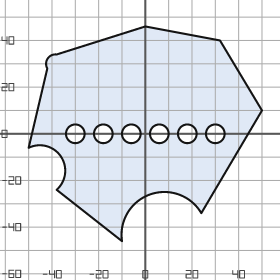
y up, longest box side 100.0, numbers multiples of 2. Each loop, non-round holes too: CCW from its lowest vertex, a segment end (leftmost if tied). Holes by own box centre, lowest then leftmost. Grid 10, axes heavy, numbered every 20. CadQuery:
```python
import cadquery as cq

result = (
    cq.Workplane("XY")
    .moveTo(-10.0, -46.0)
    .threePointArc((2.0, -26.0), (24.0, -34.0))
    .lineTo(50.0, 10.0)
    .lineTo(32.0, 40.0)
    .lineTo(0.0, 46.0)
    .lineTo(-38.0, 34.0)
    .threePointArc((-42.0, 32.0), (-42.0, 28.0))
    .lineTo(-50.0, -6.0)
    .threePointArc((-36.0, -10.0), (-38.0, -24.0))
    .close()
    .moveTo(-30.0, 0.0)
    .circle(4.0)
    .moveTo(-18.0, 0.0)
    .circle(4.0)
    .moveTo(-6.0, 0.0)
    .circle(4.0)
    .moveTo(6.0, 0.0)
    .circle(4.0)
    .moveTo(18.0, 0.0)
    .circle(4.0)
    .moveTo(30.0, 0.0)
    .circle(4.0)
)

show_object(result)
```